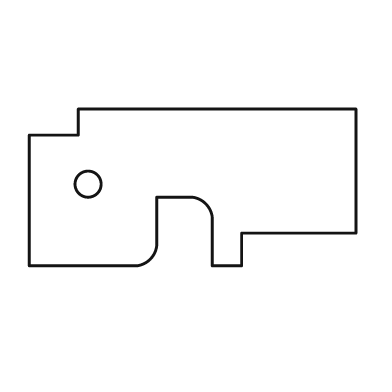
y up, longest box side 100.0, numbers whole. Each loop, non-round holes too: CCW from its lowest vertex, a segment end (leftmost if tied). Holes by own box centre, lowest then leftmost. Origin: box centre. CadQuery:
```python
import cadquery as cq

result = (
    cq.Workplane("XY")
    .moveTo(-50.0, -24.0)
    .lineTo(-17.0, -24.0)
    .threePointArc((-13.0, -22.0), (-11.0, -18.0))
    .lineTo(-11.0, -3.0)
    .lineTo(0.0, -3.0)
    .threePointArc((4.0, -5.0), (6.0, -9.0))
    .lineTo(6.0, -24.0)
    .lineTo(15.0, -24.0)
    .lineTo(15.0, -14.0)
    .lineTo(50.0, -14.0)
    .lineTo(50.0, 24.0)
    .lineTo(-35.0, 24.0)
    .lineTo(-35.0, 16.0)
    .lineTo(-50.0, 16.0)
    .close()
    .moveTo(-32.0, 1.0)
    .circle(4.0)
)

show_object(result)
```